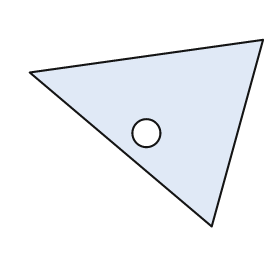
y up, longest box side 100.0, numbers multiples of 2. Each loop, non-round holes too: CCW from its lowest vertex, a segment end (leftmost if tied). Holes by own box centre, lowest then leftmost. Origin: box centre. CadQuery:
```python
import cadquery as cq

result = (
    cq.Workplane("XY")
    .moveTo(28.0, -40.0)
    .lineTo(50.0, 40.0)
    .lineTo(-50.0, 26.0)
    .close()
    .moveTo(0.0, 0.0)
    .circle(6.0)
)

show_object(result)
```